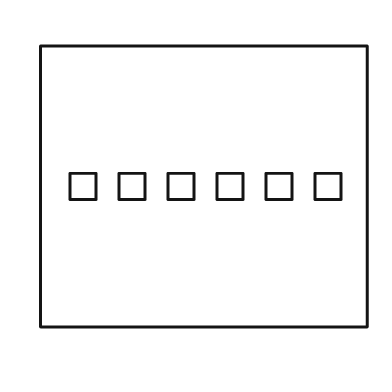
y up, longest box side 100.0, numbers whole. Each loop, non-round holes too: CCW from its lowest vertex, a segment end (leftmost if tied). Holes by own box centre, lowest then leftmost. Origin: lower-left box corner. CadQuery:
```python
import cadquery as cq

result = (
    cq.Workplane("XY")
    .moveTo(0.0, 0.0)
    .lineTo(100.0, 0.0)
    .lineTo(100.0, 86.0)
    .lineTo(0.0, 86.0)
    .close()
    .moveTo(9.0, 39.0)
    .lineTo(17.0, 39.0)
    .lineTo(17.0, 47.0)
    .lineTo(9.0, 47.0)
    .close()
    .moveTo(24.0, 39.0)
    .lineTo(32.0, 39.0)
    .lineTo(32.0, 47.0)
    .lineTo(24.0, 47.0)
    .close()
    .moveTo(39.0, 39.0)
    .lineTo(47.0, 39.0)
    .lineTo(47.0, 47.0)
    .lineTo(39.0, 47.0)
    .close()
    .moveTo(54.0, 39.0)
    .lineTo(62.0, 39.0)
    .lineTo(62.0, 47.0)
    .lineTo(54.0, 47.0)
    .close()
    .moveTo(69.0, 39.0)
    .lineTo(77.0, 39.0)
    .lineTo(77.0, 47.0)
    .lineTo(69.0, 47.0)
    .close()
    .moveTo(84.0, 39.0)
    .lineTo(92.0, 39.0)
    .lineTo(92.0, 47.0)
    .lineTo(84.0, 47.0)
    .close()
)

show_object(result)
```